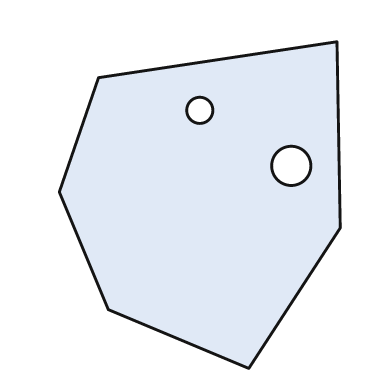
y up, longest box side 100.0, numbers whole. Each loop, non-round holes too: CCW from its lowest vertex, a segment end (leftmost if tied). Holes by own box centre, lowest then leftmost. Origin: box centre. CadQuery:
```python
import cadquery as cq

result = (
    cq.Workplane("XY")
    .moveTo(15.0, -50.0)
    .lineTo(43.0, -7.0)
    .lineTo(42.0, 50.0)
    .lineTo(-31.0, 39.0)
    .lineTo(-43.0, 4.0)
    .lineTo(-28.0, -32.0)
    .close()
    .moveTo(28.0, 12.0)
    .circle(6.0)
    .moveTo(0.0, 29.0)
    .circle(4.0)
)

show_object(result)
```